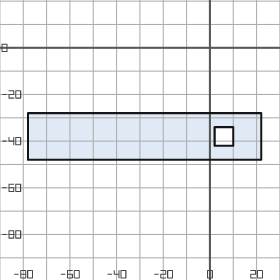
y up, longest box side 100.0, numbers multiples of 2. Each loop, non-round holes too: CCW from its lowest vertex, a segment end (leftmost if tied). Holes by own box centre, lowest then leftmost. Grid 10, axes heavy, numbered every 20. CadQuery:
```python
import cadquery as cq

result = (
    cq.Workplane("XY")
    .moveTo(-78.0, -48.0)
    .lineTo(22.0, -48.0)
    .lineTo(22.0, -28.0)
    .lineTo(-78.0, -28.0)
    .close()
    .moveTo(2.0, -42.0)
    .lineTo(10.0, -42.0)
    .lineTo(10.0, -34.0)
    .lineTo(2.0, -34.0)
    .close()
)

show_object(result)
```